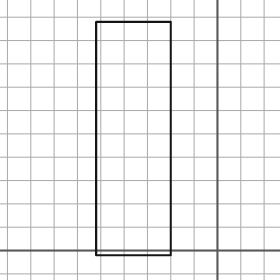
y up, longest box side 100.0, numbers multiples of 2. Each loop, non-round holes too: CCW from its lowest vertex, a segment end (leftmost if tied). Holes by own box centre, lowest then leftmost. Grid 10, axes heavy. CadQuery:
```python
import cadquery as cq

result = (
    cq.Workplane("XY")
    .moveTo(-52.0, -2.0)
    .lineTo(-20.0, -2.0)
    .lineTo(-20.0, 98.0)
    .lineTo(-52.0, 98.0)
    .close()
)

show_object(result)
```